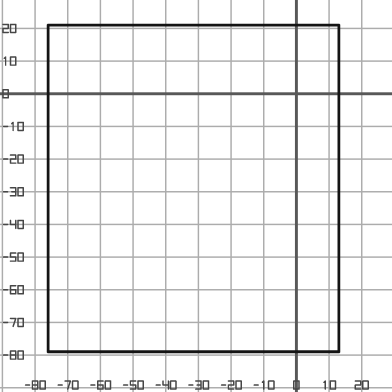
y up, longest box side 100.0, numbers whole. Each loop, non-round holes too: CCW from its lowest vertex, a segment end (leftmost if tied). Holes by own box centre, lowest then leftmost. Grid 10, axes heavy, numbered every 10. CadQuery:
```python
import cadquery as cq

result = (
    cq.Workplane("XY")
    .moveTo(-76.0, -79.0)
    .lineTo(13.0, -79.0)
    .lineTo(13.0, 21.0)
    .lineTo(-76.0, 21.0)
    .close()
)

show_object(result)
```